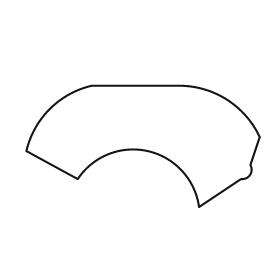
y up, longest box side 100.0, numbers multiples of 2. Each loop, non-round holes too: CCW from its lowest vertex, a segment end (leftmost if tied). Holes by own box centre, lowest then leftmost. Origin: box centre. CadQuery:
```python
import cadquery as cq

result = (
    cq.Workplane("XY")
    .moveTo(24.0, -26.0)
    .lineTo(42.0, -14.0)
    .threePointArc((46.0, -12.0), (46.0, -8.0))
    .lineTo(50.0, 4.0)
    .threePointArc((36.0, 20.0), (16.0, 26.0))
    .lineTo(-22.0, 26.0)
    .threePointArc((-40.0, 16.0), (-50.0, -2.0))
    .lineTo(-28.0, -14.0)
    .threePointArc((2.0, -2.0), (24.0, -26.0))
    .close()
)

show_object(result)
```